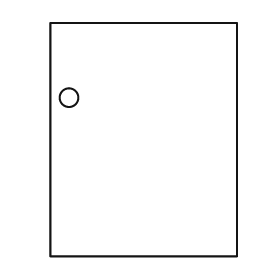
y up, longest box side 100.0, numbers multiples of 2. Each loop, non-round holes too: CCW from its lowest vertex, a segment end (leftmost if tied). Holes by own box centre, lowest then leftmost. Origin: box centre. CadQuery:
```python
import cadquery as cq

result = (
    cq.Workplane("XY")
    .moveTo(-40.0, -50.0)
    .lineTo(40.0, -50.0)
    .lineTo(40.0, 50.0)
    .lineTo(-40.0, 50.0)
    .close()
    .moveTo(-32.0, 18.0)
    .circle(4.0)
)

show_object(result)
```